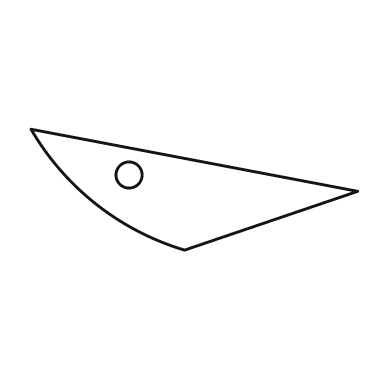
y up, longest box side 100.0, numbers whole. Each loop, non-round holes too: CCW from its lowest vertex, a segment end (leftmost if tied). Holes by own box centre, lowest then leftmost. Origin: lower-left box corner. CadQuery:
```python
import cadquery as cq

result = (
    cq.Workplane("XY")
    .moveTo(47.0, 0.0)
    .lineTo(100.0, 18.0)
    .lineTo(0.0, 37.0)
    .threePointArc((20.0, 14.0), (47.0, 0.0))
    .close()
    .moveTo(30.0, 23.0)
    .circle(4.0)
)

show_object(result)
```